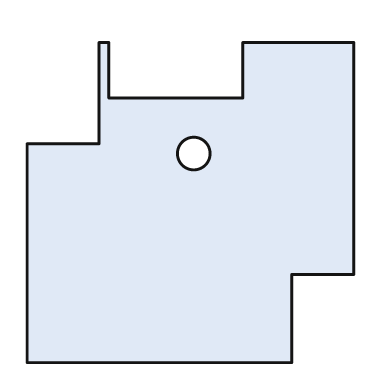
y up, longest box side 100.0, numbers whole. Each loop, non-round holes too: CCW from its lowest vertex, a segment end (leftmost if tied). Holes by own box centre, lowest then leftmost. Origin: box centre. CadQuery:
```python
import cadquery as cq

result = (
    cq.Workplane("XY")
    .moveTo(-50.0, -49.0)
    .lineTo(31.0, -49.0)
    .lineTo(31.0, -22.0)
    .lineTo(50.0, -22.0)
    .lineTo(50.0, 49.0)
    .lineTo(16.0, 49.0)
    .lineTo(16.0, 32.0)
    .lineTo(-25.0, 32.0)
    .lineTo(-25.0, 49.0)
    .lineTo(-28.0, 49.0)
    .lineTo(-28.0, 18.0)
    .lineTo(-50.0, 18.0)
    .close()
    .moveTo(1.0, 15.0)
    .circle(5.0)
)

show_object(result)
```